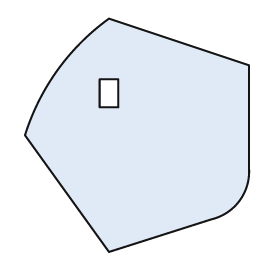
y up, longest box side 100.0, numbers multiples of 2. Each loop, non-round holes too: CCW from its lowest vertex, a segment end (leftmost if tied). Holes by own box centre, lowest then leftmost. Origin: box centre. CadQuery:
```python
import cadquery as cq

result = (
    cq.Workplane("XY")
    .moveTo(-12.0, -50.0)
    .lineTo(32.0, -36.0)
    .threePointArc((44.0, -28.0), (48.0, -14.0))
    .lineTo(48.0, 30.0)
    .lineTo(-12.0, 50.0)
    .threePointArc((-34.0, 28.0), (-48.0, 0.0))
    .close()
    .moveTo(-16.0, 12.0)
    .lineTo(-8.0, 12.0)
    .lineTo(-8.0, 24.0)
    .lineTo(-16.0, 24.0)
    .close()
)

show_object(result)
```